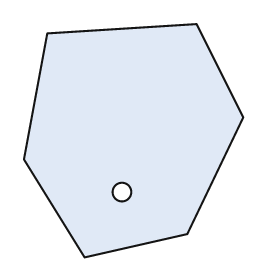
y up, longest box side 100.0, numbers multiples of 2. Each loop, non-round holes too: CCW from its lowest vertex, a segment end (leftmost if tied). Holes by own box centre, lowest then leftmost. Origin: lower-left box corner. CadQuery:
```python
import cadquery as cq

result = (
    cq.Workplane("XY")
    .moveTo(26.0, 0.0)
    .lineTo(70.0, 10.0)
    .lineTo(94.0, 60.0)
    .lineTo(74.0, 100.0)
    .lineTo(10.0, 96.0)
    .lineTo(0.0, 42.0)
    .close()
    .moveTo(42.0, 28.0)
    .circle(4.0)
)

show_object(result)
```